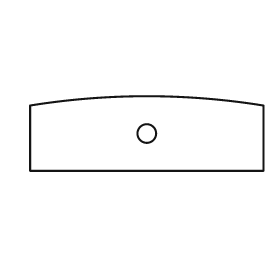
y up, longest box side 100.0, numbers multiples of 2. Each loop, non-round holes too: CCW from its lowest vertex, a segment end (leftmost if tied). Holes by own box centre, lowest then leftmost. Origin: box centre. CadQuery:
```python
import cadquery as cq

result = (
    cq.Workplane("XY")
    .moveTo(-50.0, -16.0)
    .lineTo(50.0, -16.0)
    .lineTo(50.0, 12.0)
    .threePointArc((0.0, 16.0), (-50.0, 12.0))
    .close()
    .moveTo(0.0, 0.0)
    .circle(4.0)
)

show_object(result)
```